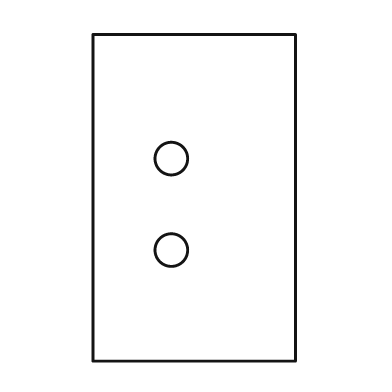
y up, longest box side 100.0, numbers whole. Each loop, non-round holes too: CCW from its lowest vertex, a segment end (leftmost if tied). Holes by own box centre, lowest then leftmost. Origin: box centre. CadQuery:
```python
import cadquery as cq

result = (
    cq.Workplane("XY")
    .moveTo(-31.0, -50.0)
    .lineTo(31.0, -50.0)
    .lineTo(31.0, 50.0)
    .lineTo(-31.0, 50.0)
    .close()
    .moveTo(-7.0, -16.0)
    .circle(5.0)
    .moveTo(-7.0, 12.0)
    .circle(5.0)
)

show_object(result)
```